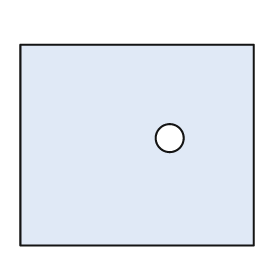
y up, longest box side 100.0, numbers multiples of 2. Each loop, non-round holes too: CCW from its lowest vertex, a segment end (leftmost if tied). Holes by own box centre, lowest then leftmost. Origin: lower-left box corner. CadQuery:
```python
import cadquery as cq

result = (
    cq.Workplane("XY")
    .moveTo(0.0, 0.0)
    .lineTo(100.0, 0.0)
    .lineTo(100.0, 86.0)
    .lineTo(0.0, 86.0)
    .close()
    .moveTo(64.0, 46.0)
    .circle(6.0)
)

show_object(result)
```